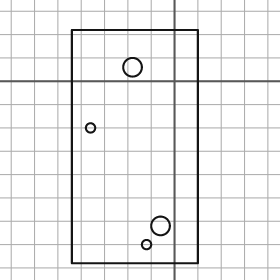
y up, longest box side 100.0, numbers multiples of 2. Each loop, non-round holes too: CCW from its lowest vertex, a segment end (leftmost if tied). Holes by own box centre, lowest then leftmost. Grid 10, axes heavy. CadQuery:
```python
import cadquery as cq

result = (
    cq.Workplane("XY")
    .moveTo(-44.0, -78.0)
    .lineTo(10.0, -78.0)
    .lineTo(10.0, 22.0)
    .lineTo(-44.0, 22.0)
    .close()
    .moveTo(-12.0, -70.0)
    .circle(2.0)
    .moveTo(-6.0, -62.0)
    .circle(4.0)
    .moveTo(-36.0, -20.0)
    .circle(2.0)
    .moveTo(-18.0, 6.0)
    .circle(4.0)
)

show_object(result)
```